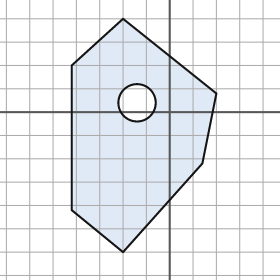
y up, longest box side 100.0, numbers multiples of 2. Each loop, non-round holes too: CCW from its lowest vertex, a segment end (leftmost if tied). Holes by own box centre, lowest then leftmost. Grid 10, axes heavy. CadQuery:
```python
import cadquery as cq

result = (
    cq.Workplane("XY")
    .moveTo(-20.0, -60.0)
    .lineTo(14.0, -22.0)
    .lineTo(20.0, 8.0)
    .lineTo(-20.0, 40.0)
    .lineTo(-42.0, 20.0)
    .lineTo(-42.0, -42.0)
    .close()
    .moveTo(-14.0, 4.0)
    .circle(8.0)
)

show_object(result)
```